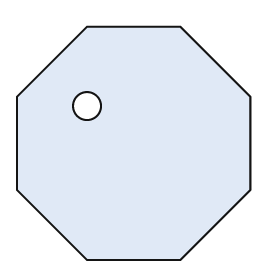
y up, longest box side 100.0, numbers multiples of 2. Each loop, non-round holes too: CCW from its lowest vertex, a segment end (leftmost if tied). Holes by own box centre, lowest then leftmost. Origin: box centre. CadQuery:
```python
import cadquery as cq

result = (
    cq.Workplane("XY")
    .moveTo(-20.0, -50.0)
    .lineTo(20.0, -50.0)
    .lineTo(50.0, -20.0)
    .lineTo(50.0, 20.0)
    .lineTo(20.0, 50.0)
    .lineTo(-20.0, 50.0)
    .lineTo(-50.0, 20.0)
    .lineTo(-50.0, -20.0)
    .close()
    .moveTo(-20.0, 16.0)
    .circle(6.0)
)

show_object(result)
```